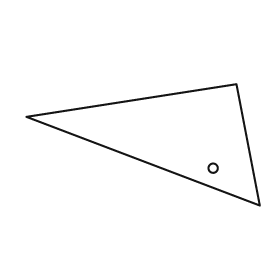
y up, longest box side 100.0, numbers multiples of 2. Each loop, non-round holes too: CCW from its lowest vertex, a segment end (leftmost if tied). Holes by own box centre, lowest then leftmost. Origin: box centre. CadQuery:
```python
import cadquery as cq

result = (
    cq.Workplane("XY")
    .moveTo(50.0, -26.0)
    .lineTo(40.0, 26.0)
    .lineTo(-50.0, 12.0)
    .close()
    .moveTo(30.0, -10.0)
    .circle(2.0)
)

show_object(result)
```